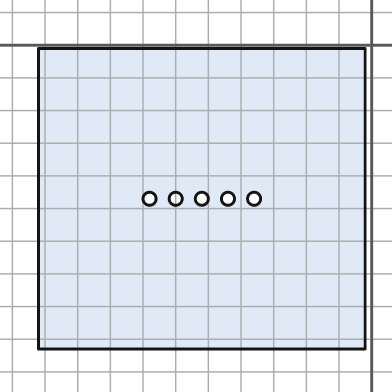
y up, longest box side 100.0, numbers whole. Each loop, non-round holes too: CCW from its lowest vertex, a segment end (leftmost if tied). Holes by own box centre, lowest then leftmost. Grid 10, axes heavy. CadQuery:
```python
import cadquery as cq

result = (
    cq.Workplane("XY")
    .moveTo(-102.0, -93.0)
    .lineTo(-2.0, -93.0)
    .lineTo(-2.0, -1.0)
    .lineTo(-102.0, -1.0)
    .close()
    .moveTo(-68.0, -47.0)
    .circle(2.0)
    .moveTo(-60.0, -47.0)
    .circle(2.0)
    .moveTo(-52.0, -47.0)
    .circle(2.0)
    .moveTo(-44.0, -47.0)
    .circle(2.0)
    .moveTo(-36.0, -47.0)
    .circle(2.0)
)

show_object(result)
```